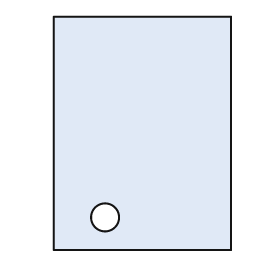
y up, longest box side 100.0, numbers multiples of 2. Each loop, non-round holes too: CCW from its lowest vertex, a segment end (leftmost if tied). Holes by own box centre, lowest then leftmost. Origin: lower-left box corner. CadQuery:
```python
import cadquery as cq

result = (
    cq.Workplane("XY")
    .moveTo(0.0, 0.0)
    .lineTo(76.0, 0.0)
    .lineTo(76.0, 100.0)
    .lineTo(0.0, 100.0)
    .close()
    .moveTo(22.0, 14.0)
    .circle(6.0)
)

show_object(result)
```